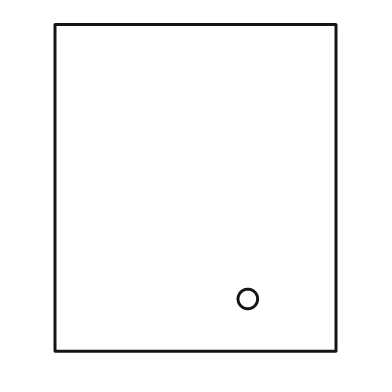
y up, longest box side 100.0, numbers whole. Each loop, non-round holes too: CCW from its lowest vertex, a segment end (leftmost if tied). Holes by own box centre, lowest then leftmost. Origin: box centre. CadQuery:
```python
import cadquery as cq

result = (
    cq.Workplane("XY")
    .moveTo(-43.0, -50.0)
    .lineTo(43.0, -50.0)
    .lineTo(43.0, 50.0)
    .lineTo(-43.0, 50.0)
    .close()
    .moveTo(16.0, -34.0)
    .circle(3.0)
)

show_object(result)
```